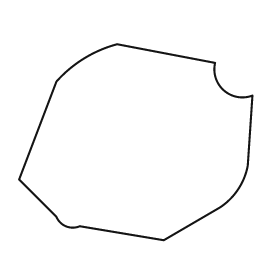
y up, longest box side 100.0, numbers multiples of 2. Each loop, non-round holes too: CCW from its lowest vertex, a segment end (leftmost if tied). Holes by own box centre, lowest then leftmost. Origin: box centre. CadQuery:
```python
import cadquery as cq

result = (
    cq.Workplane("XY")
    .moveTo(12.0, -42.0)
    .lineTo(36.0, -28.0)
    .threePointArc((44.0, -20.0), (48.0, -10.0))
    .lineTo(50.0, 20.0)
    .threePointArc((38.0, 22.0), (34.0, 34.0))
    .lineTo(-8.0, 42.0)
    .threePointArc((-22.0, 36.0), (-34.0, 26.0))
    .lineTo(-50.0, -16.0)
    .lineTo(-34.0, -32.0)
    .threePointArc((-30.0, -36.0), (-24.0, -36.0))
    .close()
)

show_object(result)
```